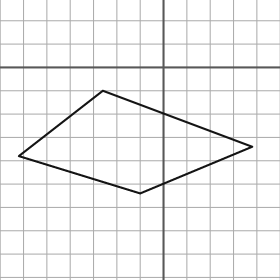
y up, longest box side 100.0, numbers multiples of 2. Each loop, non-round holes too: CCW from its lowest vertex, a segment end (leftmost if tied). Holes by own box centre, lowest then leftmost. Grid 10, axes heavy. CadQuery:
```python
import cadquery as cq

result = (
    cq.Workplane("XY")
    .moveTo(-10.0, -54.0)
    .lineTo(38.0, -34.0)
    .lineTo(-26.0, -10.0)
    .lineTo(-62.0, -38.0)
    .close()
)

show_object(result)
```